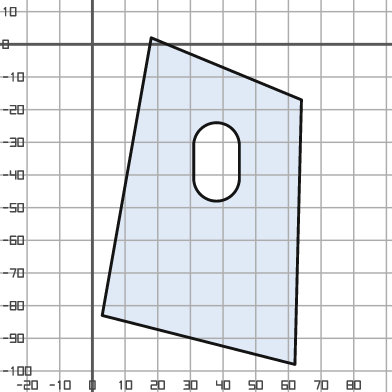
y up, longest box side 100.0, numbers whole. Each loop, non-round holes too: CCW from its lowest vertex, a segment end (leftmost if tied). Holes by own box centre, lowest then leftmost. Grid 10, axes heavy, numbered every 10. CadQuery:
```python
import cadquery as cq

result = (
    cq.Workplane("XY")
    .moveTo(62.0, -98.0)
    .lineTo(64.0, -17.0)
    .lineTo(18.0, 2.0)
    .lineTo(3.0, -83.0)
    .close()
    .moveTo(31.0, -41.0)
    .threePointArc((38.0, -48.0), (45.0, -41.0))
    .lineTo(45.0, -31.0)
    .threePointArc((38.0, -24.0), (31.0, -31.0))
    .close()
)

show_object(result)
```